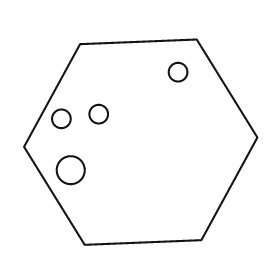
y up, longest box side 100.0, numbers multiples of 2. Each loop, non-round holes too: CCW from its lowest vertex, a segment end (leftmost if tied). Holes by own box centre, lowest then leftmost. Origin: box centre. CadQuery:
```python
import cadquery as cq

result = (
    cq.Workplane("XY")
    .moveTo(-24.0, -44.0)
    .lineTo(26.0, -42.0)
    .lineTo(50.0, 2.0)
    .lineTo(24.0, 44.0)
    .lineTo(-26.0, 42.0)
    .lineTo(-50.0, -2.0)
    .close()
    .moveTo(-30.0, -12.0)
    .circle(6.0)
    .moveTo(-34.0, 10.0)
    .circle(4.0)
    .moveTo(-18.0, 12.0)
    .circle(4.0)
    .moveTo(16.0, 30.0)
    .circle(4.0)
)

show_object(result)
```